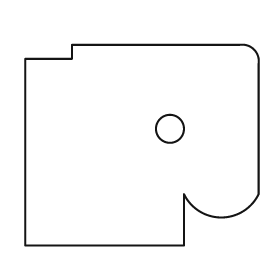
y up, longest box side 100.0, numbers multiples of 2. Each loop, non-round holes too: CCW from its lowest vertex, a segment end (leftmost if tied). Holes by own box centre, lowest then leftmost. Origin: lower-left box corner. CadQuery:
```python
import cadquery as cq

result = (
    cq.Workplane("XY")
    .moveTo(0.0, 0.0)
    .lineTo(68.0, 0.0)
    .lineTo(68.0, 22.0)
    .threePointArc((84.0, 12.0), (100.0, 22.0))
    .lineTo(100.0, 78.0)
    .threePointArc((98.0, 84.0), (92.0, 86.0))
    .lineTo(20.0, 86.0)
    .lineTo(20.0, 80.0)
    .lineTo(0.0, 80.0)
    .close()
    .moveTo(62.0, 50.0)
    .circle(6.0)
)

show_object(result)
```